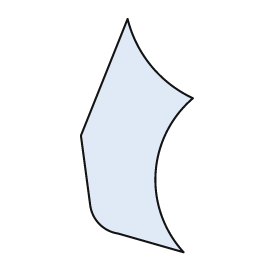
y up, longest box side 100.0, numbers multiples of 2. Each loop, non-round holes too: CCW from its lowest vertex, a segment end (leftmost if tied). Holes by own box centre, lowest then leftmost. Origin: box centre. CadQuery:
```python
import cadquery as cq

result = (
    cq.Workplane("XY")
    .moveTo(20.0, -50.0)
    .threePointArc((8.0, -16.0), (24.0, 16.0))
    .threePointArc((6.0, 30.0), (-4.0, 50.0))
    .lineTo(-24.0, 0.0)
    .lineTo(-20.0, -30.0)
    .threePointArc((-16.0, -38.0), (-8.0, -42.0))
    .close()
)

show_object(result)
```